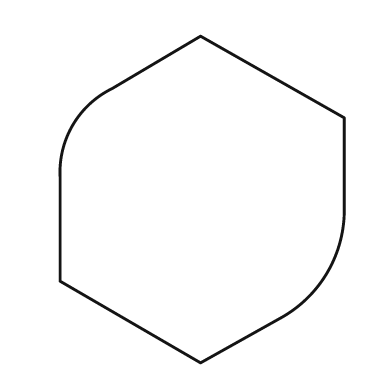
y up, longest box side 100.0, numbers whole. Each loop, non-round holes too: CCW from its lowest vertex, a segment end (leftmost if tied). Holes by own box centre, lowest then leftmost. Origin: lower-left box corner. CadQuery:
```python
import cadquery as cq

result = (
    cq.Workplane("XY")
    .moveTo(43.0, 0.0)
    .lineTo(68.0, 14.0)
    .threePointArc((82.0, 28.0), (87.0, 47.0))
    .lineTo(87.0, 75.0)
    .lineTo(43.0, 100.0)
    .lineTo(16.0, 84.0)
    .threePointArc((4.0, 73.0), (0.0, 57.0))
    .lineTo(0.0, 25.0)
    .close()
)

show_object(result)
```